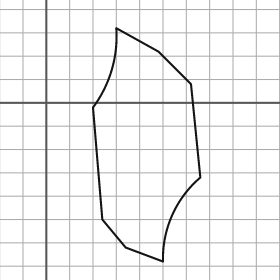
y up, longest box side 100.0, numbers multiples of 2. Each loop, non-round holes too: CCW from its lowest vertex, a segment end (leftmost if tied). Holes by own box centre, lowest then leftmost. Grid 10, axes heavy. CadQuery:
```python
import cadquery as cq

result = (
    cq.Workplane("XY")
    .moveTo(50.0, -68.0)
    .threePointArc((54.0, -48.0), (66.0, -32.0))
    .lineTo(62.0, 8.0)
    .lineTo(48.0, 22.0)
    .lineTo(30.0, 32.0)
    .threePointArc((28.0, 14.0), (20.0, -2.0))
    .lineTo(24.0, -50.0)
    .lineTo(34.0, -62.0)
    .close()
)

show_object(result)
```